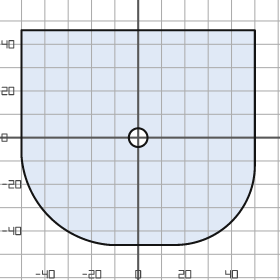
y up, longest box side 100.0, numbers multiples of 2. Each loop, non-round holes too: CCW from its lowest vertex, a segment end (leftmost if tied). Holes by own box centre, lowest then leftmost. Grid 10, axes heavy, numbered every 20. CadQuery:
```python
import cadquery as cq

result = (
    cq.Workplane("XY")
    .moveTo(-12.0, -46.0)
    .lineTo(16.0, -46.0)
    .threePointArc((40.0, -36.0), (50.0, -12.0))
    .lineTo(50.0, 46.0)
    .lineTo(-50.0, 46.0)
    .lineTo(-50.0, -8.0)
    .threePointArc((-38.0, -34.0), (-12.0, -46.0))
    .close()
    .moveTo(0.0, 0.0)
    .circle(4.0)
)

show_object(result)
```